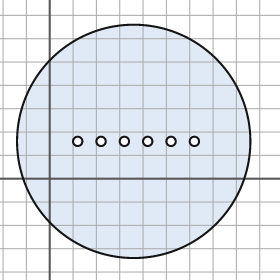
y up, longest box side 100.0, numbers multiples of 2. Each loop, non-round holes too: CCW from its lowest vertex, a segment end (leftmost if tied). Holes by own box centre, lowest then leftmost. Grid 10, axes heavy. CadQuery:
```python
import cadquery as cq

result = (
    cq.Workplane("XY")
    .moveTo(36.0, 16.0)
    .circle(50.0)
    .moveTo(12.0, 16.0)
    .circle(2.0)
    .moveTo(22.0, 16.0)
    .circle(2.0)
    .moveTo(32.0, 16.0)
    .circle(2.0)
    .moveTo(42.0, 16.0)
    .circle(2.0)
    .moveTo(52.0, 16.0)
    .circle(2.0)
    .moveTo(62.0, 16.0)
    .circle(2.0)
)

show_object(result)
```